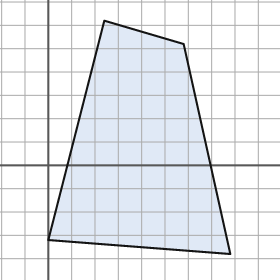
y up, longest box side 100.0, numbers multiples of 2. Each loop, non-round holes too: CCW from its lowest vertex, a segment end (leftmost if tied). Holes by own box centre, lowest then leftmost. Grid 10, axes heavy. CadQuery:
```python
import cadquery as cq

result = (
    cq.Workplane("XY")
    .moveTo(78.0, -38.0)
    .lineTo(58.0, 52.0)
    .lineTo(24.0, 62.0)
    .lineTo(0.0, -32.0)
    .close()
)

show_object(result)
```